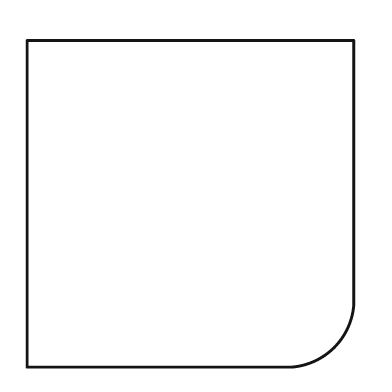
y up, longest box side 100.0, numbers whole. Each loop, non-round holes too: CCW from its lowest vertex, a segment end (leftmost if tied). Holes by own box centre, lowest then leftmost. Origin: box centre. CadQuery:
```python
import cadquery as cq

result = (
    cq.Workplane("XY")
    .moveTo(-50.0, -50.0)
    .lineTo(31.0, -50.0)
    .threePointArc((44.0, -44.0), (50.0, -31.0))
    .lineTo(50.0, 50.0)
    .lineTo(-50.0, 50.0)
    .close()
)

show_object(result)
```